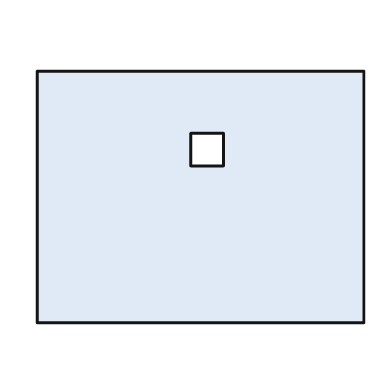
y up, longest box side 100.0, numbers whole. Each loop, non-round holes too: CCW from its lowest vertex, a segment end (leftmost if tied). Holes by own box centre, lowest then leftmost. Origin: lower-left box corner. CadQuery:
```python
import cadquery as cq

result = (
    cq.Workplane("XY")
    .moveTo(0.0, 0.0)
    .lineTo(100.0, 0.0)
    .lineTo(100.0, 77.0)
    .lineTo(0.0, 77.0)
    .close()
    .moveTo(47.0, 48.0)
    .lineTo(57.0, 48.0)
    .lineTo(57.0, 58.0)
    .lineTo(47.0, 58.0)
    .close()
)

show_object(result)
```